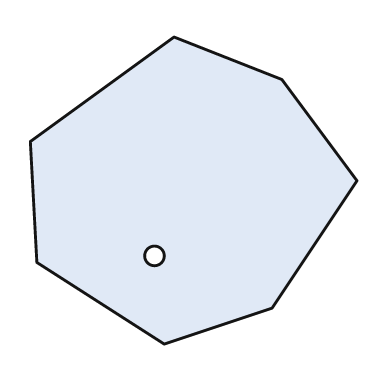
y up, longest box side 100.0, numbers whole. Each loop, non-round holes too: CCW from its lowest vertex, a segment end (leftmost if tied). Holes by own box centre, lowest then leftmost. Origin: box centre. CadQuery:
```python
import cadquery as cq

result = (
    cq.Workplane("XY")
    .moveTo(-9.0, -47.0)
    .lineTo(24.0, -36.0)
    .lineTo(50.0, 3.0)
    .lineTo(27.0, 34.0)
    .lineTo(-6.0, 47.0)
    .lineTo(-50.0, 15.0)
    .lineTo(-48.0, -22.0)
    .close()
    .moveTo(-12.0, -20.0)
    .circle(3.0)
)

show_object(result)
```